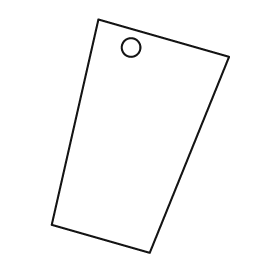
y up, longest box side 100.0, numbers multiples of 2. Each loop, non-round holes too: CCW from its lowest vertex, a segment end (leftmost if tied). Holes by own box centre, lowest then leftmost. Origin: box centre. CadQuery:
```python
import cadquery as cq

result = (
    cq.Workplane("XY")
    .moveTo(4.0, -50.0)
    .lineTo(38.0, 34.0)
    .lineTo(-18.0, 50.0)
    .lineTo(-38.0, -38.0)
    .close()
    .moveTo(-4.0, 38.0)
    .circle(4.0)
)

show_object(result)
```